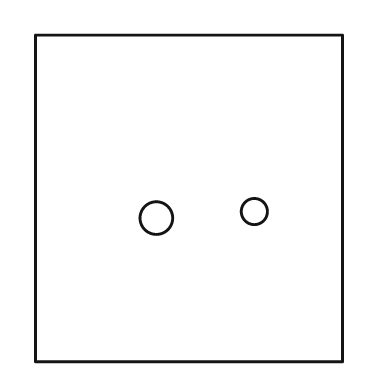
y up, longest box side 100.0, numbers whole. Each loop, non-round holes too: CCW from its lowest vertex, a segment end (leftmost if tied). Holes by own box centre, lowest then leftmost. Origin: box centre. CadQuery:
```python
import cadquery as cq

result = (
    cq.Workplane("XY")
    .moveTo(-47.0, -50.0)
    .lineTo(47.0, -50.0)
    .lineTo(47.0, 50.0)
    .lineTo(-47.0, 50.0)
    .close()
    .moveTo(-10.0, -6.0)
    .circle(5.0)
    .moveTo(20.0, -4.0)
    .circle(4.0)
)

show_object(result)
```